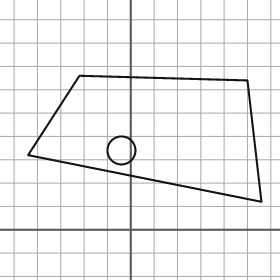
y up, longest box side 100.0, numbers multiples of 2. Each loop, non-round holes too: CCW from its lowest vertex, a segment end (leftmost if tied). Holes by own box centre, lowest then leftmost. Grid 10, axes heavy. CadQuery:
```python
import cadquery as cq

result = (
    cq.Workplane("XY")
    .moveTo(56.0, 12.0)
    .lineTo(50.0, 64.0)
    .lineTo(-22.0, 66.0)
    .lineTo(-44.0, 32.0)
    .close()
    .moveTo(-4.0, 34.0)
    .circle(6.0)
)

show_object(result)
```